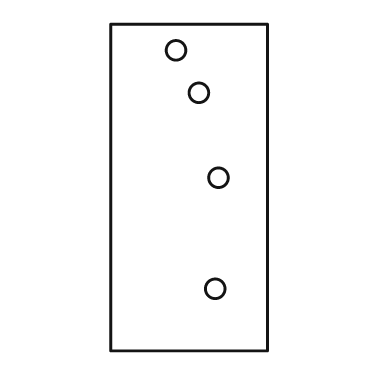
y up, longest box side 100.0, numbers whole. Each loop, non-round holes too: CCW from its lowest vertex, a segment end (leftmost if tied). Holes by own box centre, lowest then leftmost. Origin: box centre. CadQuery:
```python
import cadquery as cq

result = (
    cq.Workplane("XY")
    .moveTo(-24.0, -50.0)
    .lineTo(24.0, -50.0)
    .lineTo(24.0, 50.0)
    .lineTo(-24.0, 50.0)
    .close()
    .moveTo(8.0, -31.0)
    .circle(3.0)
    .moveTo(9.0, 3.0)
    .circle(3.0)
    .moveTo(3.0, 29.0)
    .circle(3.0)
    .moveTo(-4.0, 42.0)
    .circle(3.0)
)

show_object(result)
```